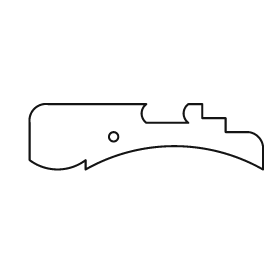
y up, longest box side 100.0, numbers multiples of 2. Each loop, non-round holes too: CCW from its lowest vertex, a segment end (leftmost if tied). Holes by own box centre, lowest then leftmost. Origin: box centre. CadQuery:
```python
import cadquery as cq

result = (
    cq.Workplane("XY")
    .moveTo(-26.0, -14.0)
    .threePointArc((12.0, -4.0), (50.0, -14.0))
    .lineTo(50.0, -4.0)
    .threePointArc((48.0, 0.0), (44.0, 2.0))
    .lineTo(34.0, 2.0)
    .lineTo(34.0, 8.0)
    .lineTo(24.0, 8.0)
    .lineTo(24.0, 14.0)
    .lineTo(18.0, 14.0)
    .threePointArc((16.0, 10.0), (18.0, 6.0))
    .lineTo(0.0, 6.0)
    .threePointArc((-2.0, 10.0), (0.0, 14.0))
    .lineTo(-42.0, 14.0)
    .threePointArc((-48.0, 12.0), (-50.0, 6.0))
    .lineTo(-50.0, -10.0)
    .threePointArc((-38.0, -14.0), (-26.0, -10.0))
    .close()
    .moveTo(-14.0, 0.0)
    .circle(2.0)
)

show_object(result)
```